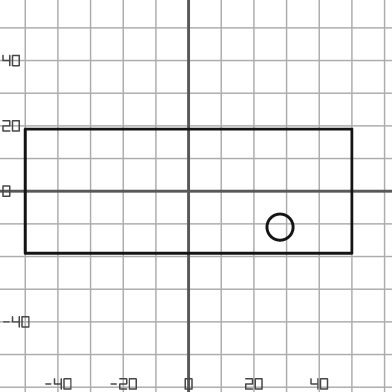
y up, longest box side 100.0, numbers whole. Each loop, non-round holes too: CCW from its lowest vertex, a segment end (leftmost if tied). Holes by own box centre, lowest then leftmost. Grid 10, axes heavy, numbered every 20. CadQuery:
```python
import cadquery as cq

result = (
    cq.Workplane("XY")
    .moveTo(-50.0, -19.0)
    .lineTo(50.0, -19.0)
    .lineTo(50.0, 19.0)
    .lineTo(-50.0, 19.0)
    .close()
    .moveTo(28.0, -11.0)
    .circle(4.0)
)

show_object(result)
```